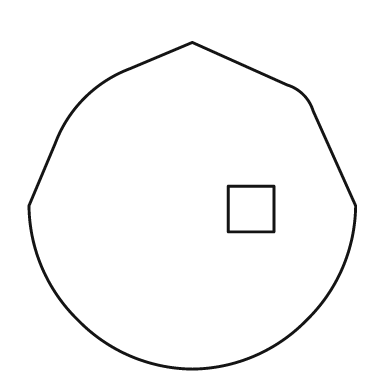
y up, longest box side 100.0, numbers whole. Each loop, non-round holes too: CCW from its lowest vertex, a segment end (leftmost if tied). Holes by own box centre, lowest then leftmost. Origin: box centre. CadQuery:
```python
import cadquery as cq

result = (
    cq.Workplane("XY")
    .moveTo(0.0, -50.0)
    .threePointArc((19.0, -46.0), (35.0, -35.0))
    .threePointArc((46.0, -19.0), (50.0, 0.0))
    .lineTo(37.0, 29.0)
    .threePointArc((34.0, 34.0), (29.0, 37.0))
    .lineTo(0.0, 50.0)
    .lineTo(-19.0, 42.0)
    .threePointArc((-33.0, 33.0), (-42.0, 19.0))
    .lineTo(-50.0, 0.0)
    .threePointArc((-46.0, -19.0), (-35.0, -35.0))
    .threePointArc((-19.0, -46.0), (0.0, -50.0))
    .close()
    .moveTo(11.0, -8.0)
    .lineTo(25.0, -8.0)
    .lineTo(25.0, 6.0)
    .lineTo(11.0, 6.0)
    .close()
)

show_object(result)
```